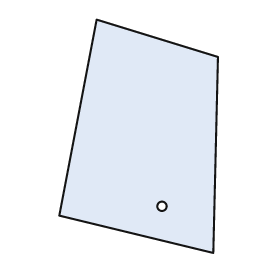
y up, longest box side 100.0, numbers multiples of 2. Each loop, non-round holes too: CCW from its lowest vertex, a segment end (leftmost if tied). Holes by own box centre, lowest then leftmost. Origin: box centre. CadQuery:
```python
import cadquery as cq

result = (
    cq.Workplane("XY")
    .moveTo(32.0, -50.0)
    .lineTo(34.0, 34.0)
    .lineTo(-18.0, 50.0)
    .lineTo(-34.0, -34.0)
    .close()
    .moveTo(10.0, -30.0)
    .circle(2.0)
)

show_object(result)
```